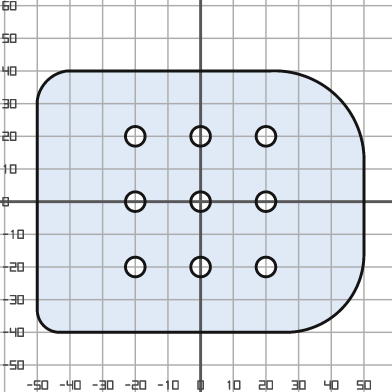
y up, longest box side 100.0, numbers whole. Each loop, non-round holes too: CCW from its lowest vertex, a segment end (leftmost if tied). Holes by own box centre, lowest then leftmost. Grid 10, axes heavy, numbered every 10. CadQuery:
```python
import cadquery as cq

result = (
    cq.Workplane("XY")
    .moveTo(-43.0, -40.0)
    .lineTo(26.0, -40.0)
    .threePointArc((43.0, -33.0), (50.0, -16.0))
    .lineTo(50.0, 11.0)
    .threePointArc((42.0, 32.0), (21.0, 40.0))
    .lineTo(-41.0, 40.0)
    .threePointArc((-47.0, 37.0), (-50.0, 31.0))
    .lineTo(-50.0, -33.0)
    .threePointArc((-48.0, -38.0), (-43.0, -40.0))
    .close()
    .moveTo(-20.0, -20.0)
    .circle(3.0)
    .moveTo(0.0, -20.0)
    .circle(3.0)
    .moveTo(20.0, -20.0)
    .circle(3.0)
    .moveTo(-20.0, 0.0)
    .circle(3.0)
    .moveTo(0.0, 0.0)
    .circle(3.0)
    .moveTo(20.0, 0.0)
    .circle(3.0)
    .moveTo(-20.0, 20.0)
    .circle(3.0)
    .moveTo(0.0, 20.0)
    .circle(3.0)
    .moveTo(20.0, 20.0)
    .circle(3.0)
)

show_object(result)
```